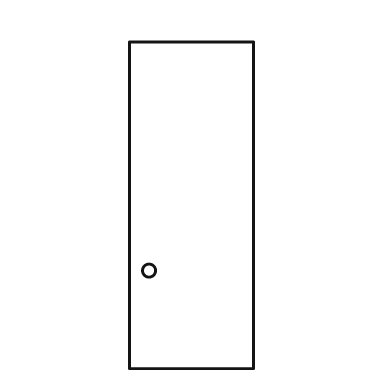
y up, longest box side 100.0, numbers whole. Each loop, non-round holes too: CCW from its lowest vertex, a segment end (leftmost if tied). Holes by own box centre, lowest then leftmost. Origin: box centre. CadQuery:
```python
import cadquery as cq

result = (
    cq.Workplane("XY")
    .moveTo(-19.0, -50.0)
    .lineTo(19.0, -50.0)
    .lineTo(19.0, 50.0)
    .lineTo(-19.0, 50.0)
    .close()
    .moveTo(-13.0, -20.0)
    .circle(2.0)
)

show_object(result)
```